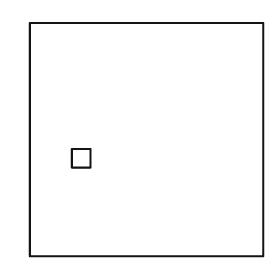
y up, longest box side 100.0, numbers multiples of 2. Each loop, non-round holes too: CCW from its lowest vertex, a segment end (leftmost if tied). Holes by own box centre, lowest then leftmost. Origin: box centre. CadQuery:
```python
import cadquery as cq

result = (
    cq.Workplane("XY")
    .moveTo(-50.0, -50.0)
    .lineTo(50.0, -50.0)
    .lineTo(50.0, 50.0)
    .lineTo(-50.0, 50.0)
    .close()
    .moveTo(-32.0, -12.0)
    .lineTo(-24.0, -12.0)
    .lineTo(-24.0, -4.0)
    .lineTo(-32.0, -4.0)
    .close()
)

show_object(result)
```